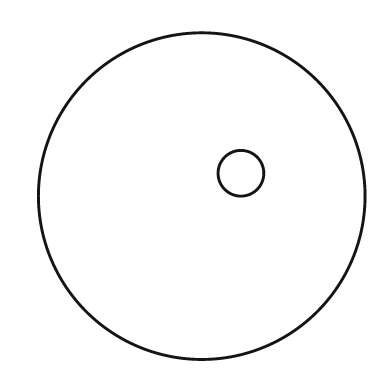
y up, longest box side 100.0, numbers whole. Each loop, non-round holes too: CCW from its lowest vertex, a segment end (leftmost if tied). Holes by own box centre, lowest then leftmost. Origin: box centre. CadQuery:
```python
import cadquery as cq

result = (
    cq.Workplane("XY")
    .moveTo(0.0, 0.0)
    .circle(50.0)
    .moveTo(12.0, 7.0)
    .circle(7.0)
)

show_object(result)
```